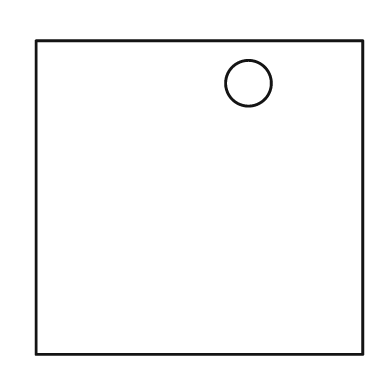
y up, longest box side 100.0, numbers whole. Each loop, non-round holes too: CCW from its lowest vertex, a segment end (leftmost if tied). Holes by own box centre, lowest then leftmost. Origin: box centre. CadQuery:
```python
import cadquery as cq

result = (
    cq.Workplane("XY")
    .moveTo(-50.0, -48.0)
    .lineTo(50.0, -48.0)
    .lineTo(50.0, 48.0)
    .lineTo(-50.0, 48.0)
    .close()
    .moveTo(15.0, 35.0)
    .circle(7.0)
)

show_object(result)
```